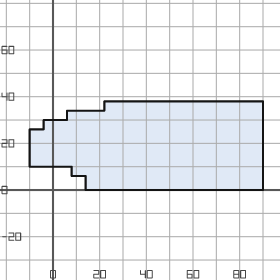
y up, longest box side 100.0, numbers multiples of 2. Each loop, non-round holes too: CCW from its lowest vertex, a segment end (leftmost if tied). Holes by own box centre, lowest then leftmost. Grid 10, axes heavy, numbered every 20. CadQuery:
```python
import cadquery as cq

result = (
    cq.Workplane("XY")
    .moveTo(14.0, 0.0)
    .lineTo(90.0, 0.0)
    .lineTo(90.0, 38.0)
    .lineTo(22.0, 38.0)
    .lineTo(22.0, 34.0)
    .lineTo(6.0, 34.0)
    .lineTo(6.0, 30.0)
    .lineTo(-4.0, 30.0)
    .lineTo(-4.0, 26.0)
    .lineTo(-10.0, 26.0)
    .lineTo(-10.0, 10.0)
    .lineTo(8.0, 10.0)
    .lineTo(8.0, 6.0)
    .lineTo(14.0, 6.0)
    .close()
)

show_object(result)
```